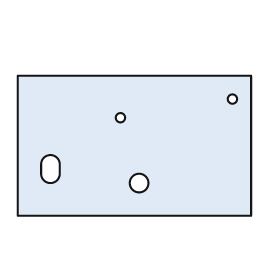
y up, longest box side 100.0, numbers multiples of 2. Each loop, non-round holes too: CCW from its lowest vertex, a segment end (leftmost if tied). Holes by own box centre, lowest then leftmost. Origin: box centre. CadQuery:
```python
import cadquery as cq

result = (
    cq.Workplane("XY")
    .moveTo(-50.0, -30.0)
    .lineTo(50.0, -30.0)
    .lineTo(50.0, 30.0)
    .lineTo(-50.0, 30.0)
    .close()
    .moveTo(2.0, -16.0)
    .circle(4.0)
    .moveTo(-40.0, -12.0)
    .threePointArc((-36.0, -16.0), (-32.0, -12.0))
    .lineTo(-32.0, -8.0)
    .threePointArc((-36.0, -4.0), (-40.0, -8.0))
    .close()
    .moveTo(-6.0, 12.0)
    .circle(2.0)
    .moveTo(42.0, 20.0)
    .circle(2.0)
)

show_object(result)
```